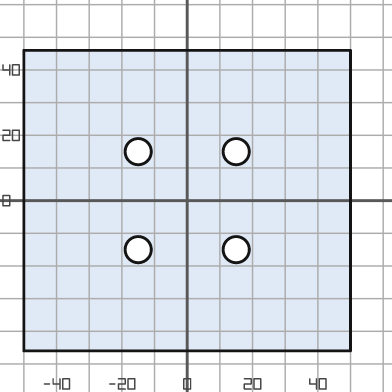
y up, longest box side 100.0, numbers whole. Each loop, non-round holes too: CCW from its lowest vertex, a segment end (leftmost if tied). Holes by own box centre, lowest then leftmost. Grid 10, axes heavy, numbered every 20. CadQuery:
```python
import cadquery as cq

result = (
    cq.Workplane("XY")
    .moveTo(-50.0, -46.0)
    .lineTo(50.0, -46.0)
    .lineTo(50.0, 46.0)
    .lineTo(-50.0, 46.0)
    .close()
    .moveTo(-15.0, -15.0)
    .circle(4.0)
    .moveTo(15.0, -15.0)
    .circle(4.0)
    .moveTo(-15.0, 15.0)
    .circle(4.0)
    .moveTo(15.0, 15.0)
    .circle(4.0)
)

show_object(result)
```